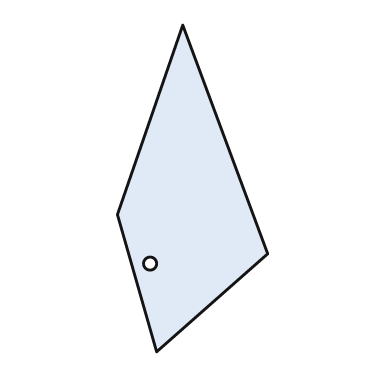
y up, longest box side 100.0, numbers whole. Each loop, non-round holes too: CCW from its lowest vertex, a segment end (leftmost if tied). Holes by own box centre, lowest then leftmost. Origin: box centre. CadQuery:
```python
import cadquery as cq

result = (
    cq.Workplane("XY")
    .moveTo(-11.0, -50.0)
    .lineTo(23.0, -20.0)
    .lineTo(-3.0, 50.0)
    .lineTo(-23.0, -8.0)
    .close()
    .moveTo(-13.0, -23.0)
    .circle(2.0)
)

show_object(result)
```